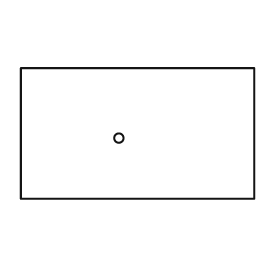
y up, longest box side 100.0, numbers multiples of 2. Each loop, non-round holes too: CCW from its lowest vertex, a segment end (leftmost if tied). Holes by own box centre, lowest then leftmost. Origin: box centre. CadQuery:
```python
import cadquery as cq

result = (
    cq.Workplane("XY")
    .moveTo(-50.0, -28.0)
    .lineTo(50.0, -28.0)
    .lineTo(50.0, 28.0)
    .lineTo(-50.0, 28.0)
    .close()
    .moveTo(-8.0, -2.0)
    .circle(2.0)
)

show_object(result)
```